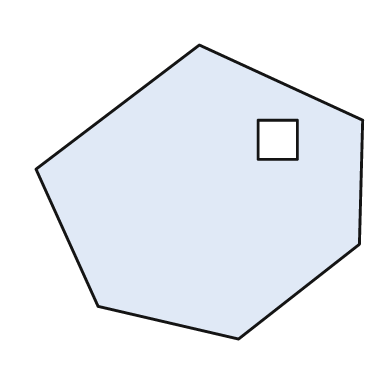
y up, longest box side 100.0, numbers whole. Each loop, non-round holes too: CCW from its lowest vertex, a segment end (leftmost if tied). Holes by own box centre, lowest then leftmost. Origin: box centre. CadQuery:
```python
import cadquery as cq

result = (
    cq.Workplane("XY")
    .moveTo(12.0, -45.0)
    .lineTo(49.0, -16.0)
    .lineTo(50.0, 22.0)
    .lineTo(0.0, 45.0)
    .lineTo(-50.0, 7.0)
    .lineTo(-31.0, -35.0)
    .close()
    .moveTo(18.0, 10.0)
    .lineTo(30.0, 10.0)
    .lineTo(30.0, 22.0)
    .lineTo(18.0, 22.0)
    .close()
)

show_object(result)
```